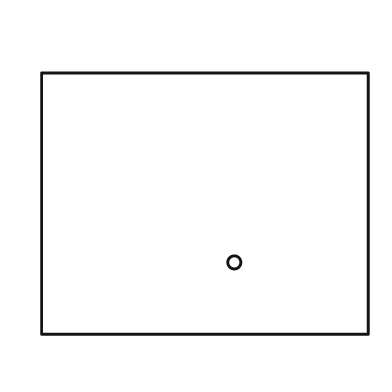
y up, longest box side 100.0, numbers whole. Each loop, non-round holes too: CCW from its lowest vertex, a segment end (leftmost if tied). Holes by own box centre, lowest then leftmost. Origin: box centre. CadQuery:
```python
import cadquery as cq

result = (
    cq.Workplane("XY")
    .moveTo(-50.0, -40.0)
    .lineTo(50.0, -40.0)
    .lineTo(50.0, 40.0)
    .lineTo(-50.0, 40.0)
    .close()
    .moveTo(9.0, -18.0)
    .circle(2.0)
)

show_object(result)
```